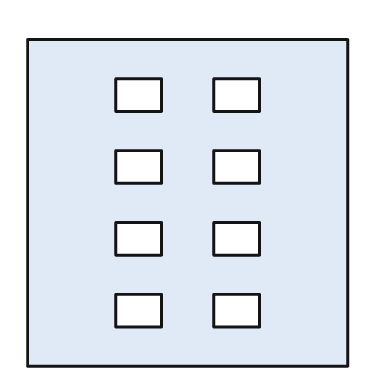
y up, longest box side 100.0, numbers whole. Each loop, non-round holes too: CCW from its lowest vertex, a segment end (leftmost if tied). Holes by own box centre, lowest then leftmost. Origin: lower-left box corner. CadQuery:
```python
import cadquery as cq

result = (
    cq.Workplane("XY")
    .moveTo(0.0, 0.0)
    .lineTo(98.0, 0.0)
    .lineTo(98.0, 100.0)
    .lineTo(0.0, 100.0)
    .close()
    .moveTo(27.0, 12.0)
    .lineTo(41.0, 12.0)
    .lineTo(41.0, 22.0)
    .lineTo(27.0, 22.0)
    .close()
    .moveTo(57.0, 12.0)
    .lineTo(71.0, 12.0)
    .lineTo(71.0, 22.0)
    .lineTo(57.0, 22.0)
    .close()
    .moveTo(27.0, 34.0)
    .lineTo(41.0, 34.0)
    .lineTo(41.0, 44.0)
    .lineTo(27.0, 44.0)
    .close()
    .moveTo(57.0, 34.0)
    .lineTo(71.0, 34.0)
    .lineTo(71.0, 44.0)
    .lineTo(57.0, 44.0)
    .close()
    .moveTo(27.0, 56.0)
    .lineTo(41.0, 56.0)
    .lineTo(41.0, 66.0)
    .lineTo(27.0, 66.0)
    .close()
    .moveTo(57.0, 56.0)
    .lineTo(71.0, 56.0)
    .lineTo(71.0, 66.0)
    .lineTo(57.0, 66.0)
    .close()
    .moveTo(27.0, 78.0)
    .lineTo(41.0, 78.0)
    .lineTo(41.0, 88.0)
    .lineTo(27.0, 88.0)
    .close()
    .moveTo(57.0, 78.0)
    .lineTo(71.0, 78.0)
    .lineTo(71.0, 88.0)
    .lineTo(57.0, 88.0)
    .close()
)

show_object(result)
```